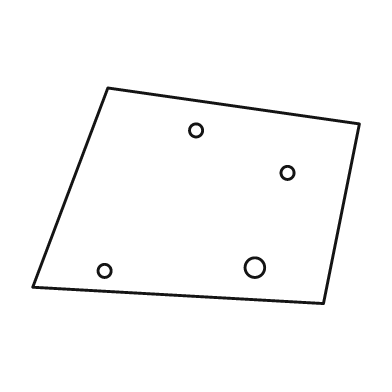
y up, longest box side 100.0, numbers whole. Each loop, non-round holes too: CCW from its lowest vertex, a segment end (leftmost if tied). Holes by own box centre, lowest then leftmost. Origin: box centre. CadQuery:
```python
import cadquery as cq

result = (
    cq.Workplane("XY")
    .moveTo(39.0, -33.0)
    .lineTo(50.0, 22.0)
    .lineTo(-27.0, 33.0)
    .lineTo(-50.0, -28.0)
    .close()
    .moveTo(-28.0, -23.0)
    .circle(2.0)
    .moveTo(18.0, -22.0)
    .circle(3.0)
    .moveTo(28.0, 7.0)
    .circle(2.0)
    .moveTo(0.0, 20.0)
    .circle(2.0)
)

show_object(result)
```